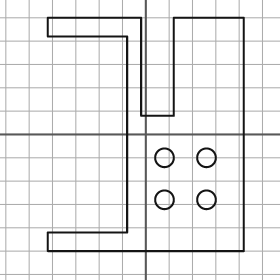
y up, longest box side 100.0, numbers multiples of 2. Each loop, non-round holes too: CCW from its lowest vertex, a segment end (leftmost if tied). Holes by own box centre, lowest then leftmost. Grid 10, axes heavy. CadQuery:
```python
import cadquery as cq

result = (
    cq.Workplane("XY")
    .moveTo(-42.0, -50.0)
    .lineTo(42.0, -50.0)
    .lineTo(42.0, 50.0)
    .lineTo(12.0, 50.0)
    .lineTo(12.0, 8.0)
    .lineTo(-2.0, 8.0)
    .lineTo(-2.0, 50.0)
    .lineTo(-42.0, 50.0)
    .lineTo(-42.0, 42.0)
    .lineTo(-8.0, 42.0)
    .lineTo(-8.0, -42.0)
    .lineTo(-42.0, -42.0)
    .close()
    .moveTo(8.0, -28.0)
    .circle(4.0)
    .moveTo(26.0, -28.0)
    .circle(4.0)
    .moveTo(8.0, -10.0)
    .circle(4.0)
    .moveTo(26.0, -10.0)
    .circle(4.0)
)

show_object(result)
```